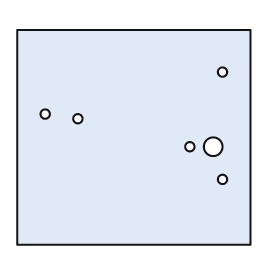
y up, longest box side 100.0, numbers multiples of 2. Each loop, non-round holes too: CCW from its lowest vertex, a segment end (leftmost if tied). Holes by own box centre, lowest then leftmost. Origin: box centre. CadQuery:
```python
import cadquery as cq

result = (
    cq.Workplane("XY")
    .moveTo(-50.0, -46.0)
    .lineTo(50.0, -46.0)
    .lineTo(50.0, 46.0)
    .lineTo(-50.0, 46.0)
    .close()
    .moveTo(38.0, -18.0)
    .circle(2.0)
    .moveTo(24.0, -4.0)
    .circle(2.0)
    .moveTo(34.0, -4.0)
    .circle(4.0)
    .moveTo(-24.0, 8.0)
    .circle(2.0)
    .moveTo(-38.0, 10.0)
    .circle(2.0)
    .moveTo(38.0, 28.0)
    .circle(2.0)
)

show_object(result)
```